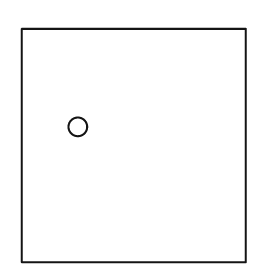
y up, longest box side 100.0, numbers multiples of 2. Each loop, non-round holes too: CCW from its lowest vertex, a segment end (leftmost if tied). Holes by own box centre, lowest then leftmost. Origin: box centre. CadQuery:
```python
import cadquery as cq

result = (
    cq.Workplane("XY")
    .moveTo(-48.0, -50.0)
    .lineTo(48.0, -50.0)
    .lineTo(48.0, 50.0)
    .lineTo(-48.0, 50.0)
    .close()
    .moveTo(-24.0, 8.0)
    .circle(4.0)
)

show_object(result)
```